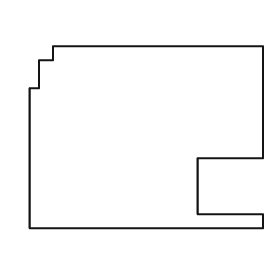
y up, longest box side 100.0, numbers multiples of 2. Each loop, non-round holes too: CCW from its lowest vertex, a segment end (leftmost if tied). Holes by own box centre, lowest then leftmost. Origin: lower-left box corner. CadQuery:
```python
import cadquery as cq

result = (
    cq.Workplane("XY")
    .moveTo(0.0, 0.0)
    .lineTo(100.0, 0.0)
    .lineTo(100.0, 6.0)
    .lineTo(72.0, 6.0)
    .lineTo(72.0, 30.0)
    .lineTo(100.0, 30.0)
    .lineTo(100.0, 78.0)
    .lineTo(10.0, 78.0)
    .lineTo(10.0, 72.0)
    .lineTo(4.0, 72.0)
    .lineTo(4.0, 60.0)
    .lineTo(0.0, 60.0)
    .close()
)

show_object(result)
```